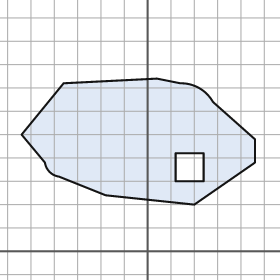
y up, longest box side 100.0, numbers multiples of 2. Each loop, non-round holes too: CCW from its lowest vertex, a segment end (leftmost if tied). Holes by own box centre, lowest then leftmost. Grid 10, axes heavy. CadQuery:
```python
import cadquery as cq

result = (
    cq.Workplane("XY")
    .moveTo(20.0, 20.0)
    .lineTo(46.0, 38.0)
    .lineTo(46.0, 48.0)
    .lineTo(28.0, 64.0)
    .threePointArc((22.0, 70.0), (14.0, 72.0))
    .lineTo(4.0, 74.0)
    .lineTo(-36.0, 72.0)
    .lineTo(-54.0, 50.0)
    .lineTo(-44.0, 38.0)
    .threePointArc((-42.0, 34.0), (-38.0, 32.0))
    .lineTo(-18.0, 24.0)
    .close()
    .moveTo(12.0, 30.0)
    .lineTo(24.0, 30.0)
    .lineTo(24.0, 42.0)
    .lineTo(12.0, 42.0)
    .close()
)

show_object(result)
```